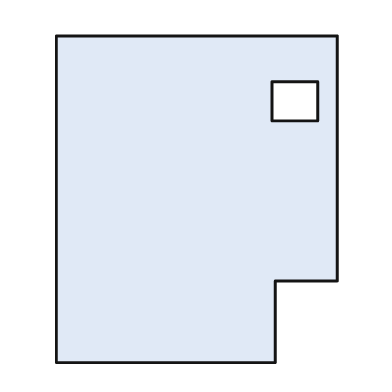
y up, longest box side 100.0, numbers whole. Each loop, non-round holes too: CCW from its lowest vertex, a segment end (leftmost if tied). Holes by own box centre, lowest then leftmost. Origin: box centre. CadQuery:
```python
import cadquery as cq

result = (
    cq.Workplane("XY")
    .moveTo(-43.0, -50.0)
    .lineTo(24.0, -50.0)
    .lineTo(24.0, -25.0)
    .lineTo(43.0, -25.0)
    .lineTo(43.0, 50.0)
    .lineTo(-43.0, 50.0)
    .close()
    .moveTo(23.0, 24.0)
    .lineTo(37.0, 24.0)
    .lineTo(37.0, 36.0)
    .lineTo(23.0, 36.0)
    .close()
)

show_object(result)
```